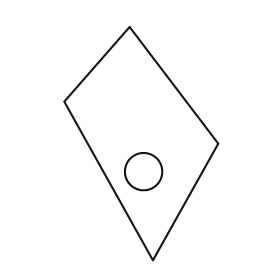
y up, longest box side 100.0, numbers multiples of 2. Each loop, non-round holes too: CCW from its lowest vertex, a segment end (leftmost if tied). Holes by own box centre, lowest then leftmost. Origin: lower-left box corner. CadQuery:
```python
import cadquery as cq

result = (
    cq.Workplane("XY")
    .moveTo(38.0, 0.0)
    .lineTo(66.0, 50.0)
    .lineTo(28.0, 100.0)
    .lineTo(0.0, 68.0)
    .close()
    .moveTo(34.0, 38.0)
    .circle(8.0)
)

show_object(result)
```